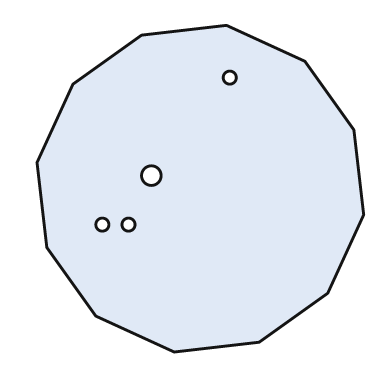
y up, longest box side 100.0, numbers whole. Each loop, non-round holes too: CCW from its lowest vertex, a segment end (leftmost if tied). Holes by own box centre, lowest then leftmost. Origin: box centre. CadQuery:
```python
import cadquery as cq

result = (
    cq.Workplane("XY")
    .moveTo(-8.0, -50.0)
    .lineTo(18.0, -47.0)
    .lineTo(39.0, -32.0)
    .lineTo(50.0, -8.0)
    .lineTo(47.0, 18.0)
    .lineTo(32.0, 39.0)
    .lineTo(8.0, 50.0)
    .lineTo(-18.0, 47.0)
    .lineTo(-39.0, 32.0)
    .lineTo(-50.0, 8.0)
    .lineTo(-47.0, -18.0)
    .lineTo(-32.0, -39.0)
    .close()
    .moveTo(-30.0, -11.0)
    .circle(2.0)
    .moveTo(-22.0, -11.0)
    .circle(2.0)
    .moveTo(-15.0, 4.0)
    .circle(3.0)
    .moveTo(9.0, 34.0)
    .circle(2.0)
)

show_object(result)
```